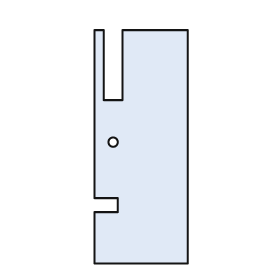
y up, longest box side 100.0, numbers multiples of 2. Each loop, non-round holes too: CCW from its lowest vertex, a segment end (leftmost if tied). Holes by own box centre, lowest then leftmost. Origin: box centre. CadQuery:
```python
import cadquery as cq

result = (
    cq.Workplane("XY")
    .moveTo(-20.0, -50.0)
    .lineTo(20.0, -50.0)
    .lineTo(20.0, 50.0)
    .lineTo(-8.0, 50.0)
    .lineTo(-8.0, 20.0)
    .lineTo(-16.0, 20.0)
    .lineTo(-16.0, 50.0)
    .lineTo(-20.0, 50.0)
    .lineTo(-20.0, -22.0)
    .lineTo(-10.0, -22.0)
    .lineTo(-10.0, -28.0)
    .lineTo(-20.0, -28.0)
    .close()
    .moveTo(-12.0, 2.0)
    .circle(2.0)
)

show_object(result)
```